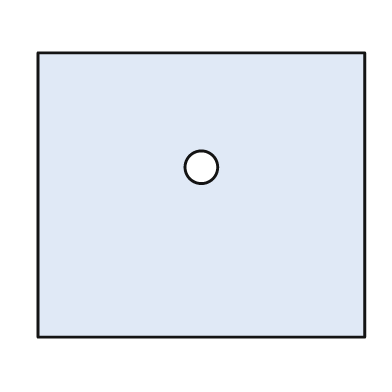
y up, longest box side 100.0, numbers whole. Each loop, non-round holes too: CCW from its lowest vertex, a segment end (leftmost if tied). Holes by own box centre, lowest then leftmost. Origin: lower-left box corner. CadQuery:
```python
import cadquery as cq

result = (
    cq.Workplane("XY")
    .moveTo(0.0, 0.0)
    .lineTo(100.0, 0.0)
    .lineTo(100.0, 87.0)
    .lineTo(0.0, 87.0)
    .close()
    .moveTo(50.0, 52.0)
    .circle(5.0)
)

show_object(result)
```